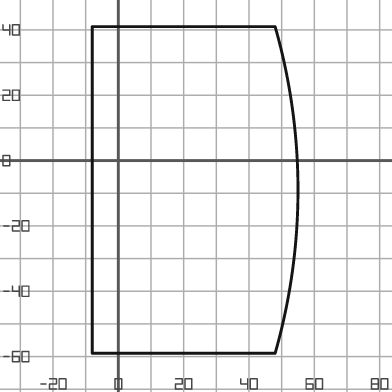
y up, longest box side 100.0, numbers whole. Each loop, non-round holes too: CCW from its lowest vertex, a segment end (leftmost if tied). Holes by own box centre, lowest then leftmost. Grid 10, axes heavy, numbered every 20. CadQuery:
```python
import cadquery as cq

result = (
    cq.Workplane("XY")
    .moveTo(-8.0, -59.0)
    .lineTo(48.0, -59.0)
    .threePointArc((55.0, -9.0), (48.0, 41.0))
    .lineTo(-8.0, 41.0)
    .close()
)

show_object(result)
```